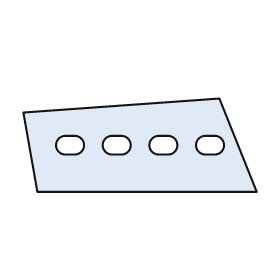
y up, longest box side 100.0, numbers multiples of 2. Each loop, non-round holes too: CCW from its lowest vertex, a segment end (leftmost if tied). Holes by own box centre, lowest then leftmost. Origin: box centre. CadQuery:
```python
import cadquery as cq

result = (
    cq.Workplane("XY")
    .moveTo(-44.0, -20.0)
    .lineTo(50.0, -20.0)
    .lineTo(34.0, 20.0)
    .lineTo(-50.0, 14.0)
    .close()
    .moveTo(-32.0, -4.0)
    .lineTo(-28.0, -4.0)
    .threePointArc((-24.0, 0.0), (-28.0, 4.0))
    .lineTo(-32.0, 4.0)
    .threePointArc((-36.0, 0.0), (-32.0, -4.0))
    .close()
    .moveTo(-12.0, -4.0)
    .lineTo(-8.0, -4.0)
    .threePointArc((-4.0, 0.0), (-8.0, 4.0))
    .lineTo(-12.0, 4.0)
    .threePointArc((-16.0, 0.0), (-12.0, -4.0))
    .close()
    .moveTo(8.0, -4.0)
    .lineTo(12.0, -4.0)
    .threePointArc((16.0, 0.0), (12.0, 4.0))
    .lineTo(8.0, 4.0)
    .threePointArc((4.0, 0.0), (8.0, -4.0))
    .close()
    .moveTo(28.0, -4.0)
    .lineTo(32.0, -4.0)
    .threePointArc((36.0, 0.0), (32.0, 4.0))
    .lineTo(28.0, 4.0)
    .threePointArc((24.0, 0.0), (28.0, -4.0))
    .close()
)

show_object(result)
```